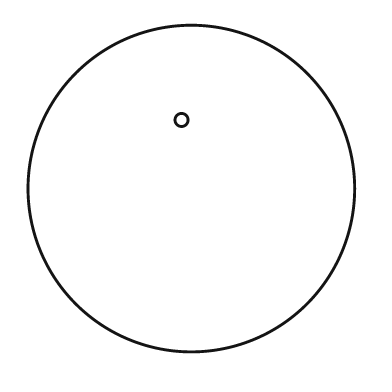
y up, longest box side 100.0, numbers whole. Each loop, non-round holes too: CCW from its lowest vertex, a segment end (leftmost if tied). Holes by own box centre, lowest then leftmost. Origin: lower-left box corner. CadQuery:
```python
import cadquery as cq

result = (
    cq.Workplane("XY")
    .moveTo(50.0, 50.0)
    .circle(50.0)
    .moveTo(47.0, 71.0)
    .circle(2.0)
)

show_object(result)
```